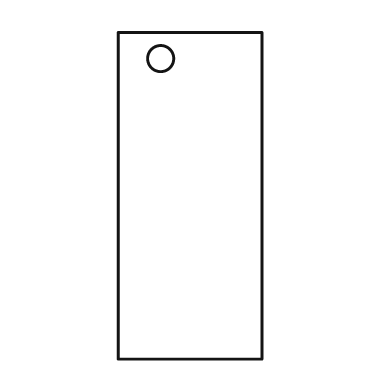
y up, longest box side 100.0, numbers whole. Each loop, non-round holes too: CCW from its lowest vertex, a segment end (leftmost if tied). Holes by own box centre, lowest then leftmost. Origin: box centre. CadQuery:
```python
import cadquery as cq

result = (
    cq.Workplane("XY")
    .moveTo(-22.0, -50.0)
    .lineTo(22.0, -50.0)
    .lineTo(22.0, 50.0)
    .lineTo(-22.0, 50.0)
    .close()
    .moveTo(-9.0, 42.0)
    .circle(4.0)
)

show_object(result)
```